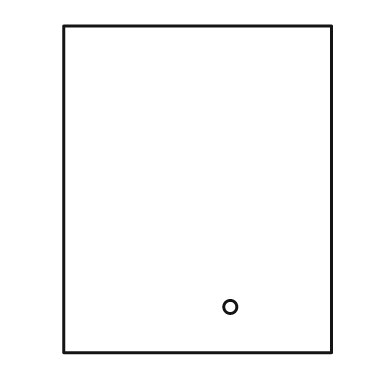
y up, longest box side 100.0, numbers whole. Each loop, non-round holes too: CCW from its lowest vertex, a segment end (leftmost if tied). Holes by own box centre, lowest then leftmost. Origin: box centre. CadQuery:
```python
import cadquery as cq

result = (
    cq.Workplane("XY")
    .moveTo(-41.0, -50.0)
    .lineTo(41.0, -50.0)
    .lineTo(41.0, 50.0)
    .lineTo(-41.0, 50.0)
    .close()
    .moveTo(10.0, -36.0)
    .circle(2.0)
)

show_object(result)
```